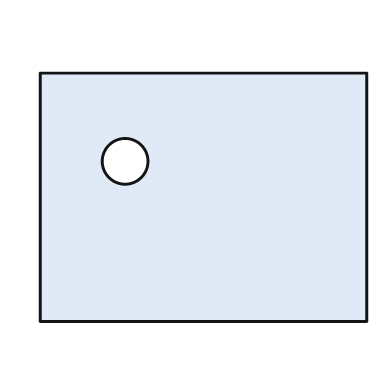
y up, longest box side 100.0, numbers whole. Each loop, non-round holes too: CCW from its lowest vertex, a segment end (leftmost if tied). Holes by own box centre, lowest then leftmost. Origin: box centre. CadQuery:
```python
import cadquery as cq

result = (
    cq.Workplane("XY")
    .moveTo(-50.0, -38.0)
    .lineTo(50.0, -38.0)
    .lineTo(50.0, 38.0)
    .lineTo(-50.0, 38.0)
    .close()
    .moveTo(-24.0, 11.0)
    .circle(7.0)
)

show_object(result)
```